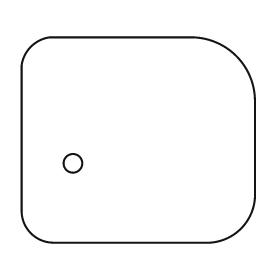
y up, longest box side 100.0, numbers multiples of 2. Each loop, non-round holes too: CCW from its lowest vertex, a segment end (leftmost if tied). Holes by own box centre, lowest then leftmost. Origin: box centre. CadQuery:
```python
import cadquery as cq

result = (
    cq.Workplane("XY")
    .moveTo(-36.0, -44.0)
    .lineTo(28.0, -44.0)
    .threePointArc((44.0, -38.0), (50.0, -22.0))
    .lineTo(50.0, 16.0)
    .threePointArc((42.0, 36.0), (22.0, 44.0))
    .lineTo(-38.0, 44.0)
    .threePointArc((-46.0, 40.0), (-50.0, 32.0))
    .lineTo(-50.0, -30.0)
    .threePointArc((-46.0, -40.0), (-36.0, -44.0))
    .close()
    .moveTo(-28.0, -10.0)
    .circle(4.0)
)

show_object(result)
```